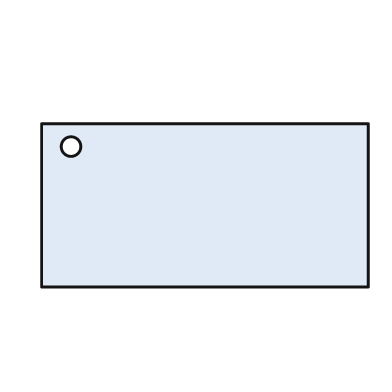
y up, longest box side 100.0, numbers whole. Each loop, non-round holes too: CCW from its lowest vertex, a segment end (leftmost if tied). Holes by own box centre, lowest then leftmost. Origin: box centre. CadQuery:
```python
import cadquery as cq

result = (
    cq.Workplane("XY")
    .moveTo(-50.0, -25.0)
    .lineTo(50.0, -25.0)
    .lineTo(50.0, 25.0)
    .lineTo(-50.0, 25.0)
    .close()
    .moveTo(-41.0, 18.0)
    .circle(3.0)
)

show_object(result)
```